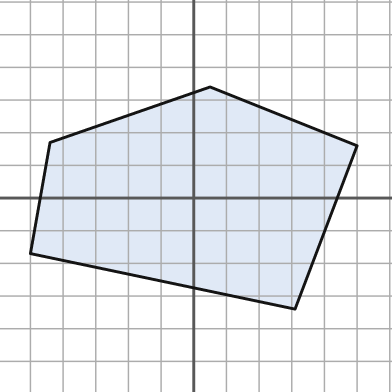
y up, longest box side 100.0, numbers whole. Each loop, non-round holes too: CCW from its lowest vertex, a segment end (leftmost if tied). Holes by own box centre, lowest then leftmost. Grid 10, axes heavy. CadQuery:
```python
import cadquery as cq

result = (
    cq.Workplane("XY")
    .moveTo(31.0, -34.0)
    .lineTo(50.0, 16.0)
    .lineTo(5.0, 34.0)
    .lineTo(-44.0, 17.0)
    .lineTo(-50.0, -17.0)
    .close()
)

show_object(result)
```